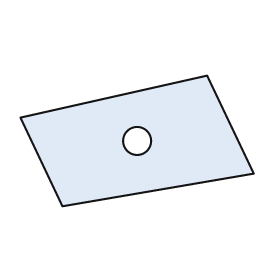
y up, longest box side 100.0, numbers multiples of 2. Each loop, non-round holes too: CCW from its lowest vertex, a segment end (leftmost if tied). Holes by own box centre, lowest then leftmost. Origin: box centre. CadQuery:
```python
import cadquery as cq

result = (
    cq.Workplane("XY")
    .moveTo(-32.0, -28.0)
    .lineTo(50.0, -14.0)
    .lineTo(30.0, 28.0)
    .lineTo(-50.0, 10.0)
    .close()
    .moveTo(0.0, 0.0)
    .circle(6.0)
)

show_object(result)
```